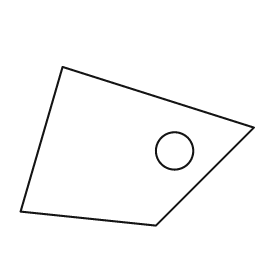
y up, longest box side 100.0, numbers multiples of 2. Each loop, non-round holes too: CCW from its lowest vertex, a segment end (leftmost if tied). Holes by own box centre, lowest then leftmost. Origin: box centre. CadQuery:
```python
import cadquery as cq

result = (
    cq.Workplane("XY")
    .moveTo(8.0, -34.0)
    .lineTo(50.0, 8.0)
    .lineTo(-32.0, 34.0)
    .lineTo(-50.0, -28.0)
    .close()
    .moveTo(16.0, -2.0)
    .circle(8.0)
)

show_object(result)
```